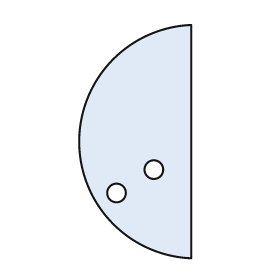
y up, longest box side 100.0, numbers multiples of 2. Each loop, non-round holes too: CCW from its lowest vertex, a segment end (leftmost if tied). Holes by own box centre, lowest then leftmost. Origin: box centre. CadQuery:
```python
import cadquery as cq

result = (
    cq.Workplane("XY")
    .moveTo(24.0, -50.0)
    .lineTo(24.0, 50.0)
    .threePointArc((-24.0, 0.0), (24.0, -50.0))
    .close()
    .moveTo(-8.0, -22.0)
    .circle(4.0)
    .moveTo(8.0, -12.0)
    .circle(4.0)
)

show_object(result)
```